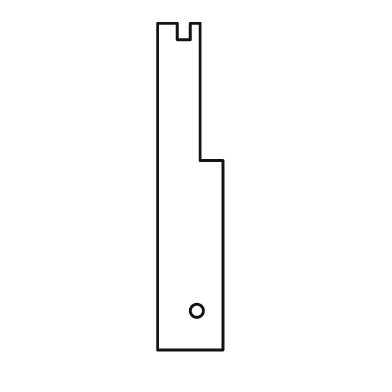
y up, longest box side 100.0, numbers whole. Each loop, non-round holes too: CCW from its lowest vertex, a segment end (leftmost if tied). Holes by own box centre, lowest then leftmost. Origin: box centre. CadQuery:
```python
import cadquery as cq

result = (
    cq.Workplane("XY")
    .moveTo(-10.0, -50.0)
    .lineTo(10.0, -50.0)
    .lineTo(10.0, 8.0)
    .lineTo(3.0, 8.0)
    .lineTo(3.0, 50.0)
    .lineTo(0.0, 50.0)
    .lineTo(0.0, 45.0)
    .lineTo(-4.0, 45.0)
    .lineTo(-4.0, 50.0)
    .lineTo(-10.0, 50.0)
    .close()
    .moveTo(2.0, -38.0)
    .circle(2.0)
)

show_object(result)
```